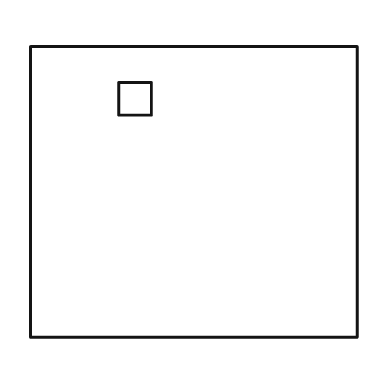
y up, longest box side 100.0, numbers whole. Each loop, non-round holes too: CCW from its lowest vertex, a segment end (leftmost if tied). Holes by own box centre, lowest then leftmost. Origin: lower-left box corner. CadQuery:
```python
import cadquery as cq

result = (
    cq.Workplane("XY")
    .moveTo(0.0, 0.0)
    .lineTo(100.0, 0.0)
    .lineTo(100.0, 89.0)
    .lineTo(0.0, 89.0)
    .close()
    .moveTo(27.0, 68.0)
    .lineTo(37.0, 68.0)
    .lineTo(37.0, 78.0)
    .lineTo(27.0, 78.0)
    .close()
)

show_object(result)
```